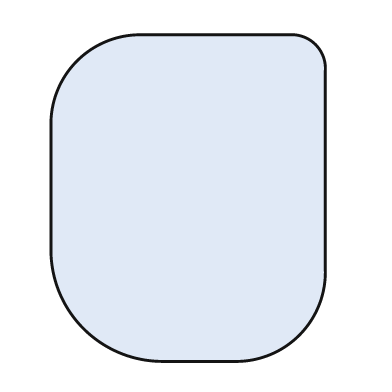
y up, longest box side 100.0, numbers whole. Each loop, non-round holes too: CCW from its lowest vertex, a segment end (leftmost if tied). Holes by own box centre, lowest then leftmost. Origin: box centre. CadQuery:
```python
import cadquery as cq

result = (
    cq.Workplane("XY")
    .moveTo(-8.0, -50.0)
    .lineTo(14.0, -50.0)
    .threePointArc((34.0, -42.0), (42.0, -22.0))
    .lineTo(42.0, 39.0)
    .threePointArc((39.0, 47.0), (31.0, 50.0))
    .lineTo(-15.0, 50.0)
    .threePointArc((-34.0, 42.0), (-42.0, 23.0))
    .lineTo(-42.0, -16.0)
    .threePointArc((-32.0, -40.0), (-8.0, -50.0))
    .close()
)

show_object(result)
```